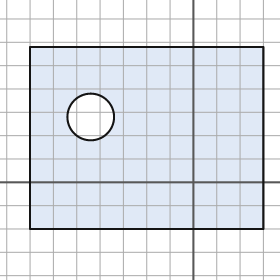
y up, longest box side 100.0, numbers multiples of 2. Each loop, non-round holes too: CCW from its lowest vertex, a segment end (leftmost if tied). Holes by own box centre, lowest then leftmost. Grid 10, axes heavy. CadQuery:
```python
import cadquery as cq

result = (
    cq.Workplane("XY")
    .moveTo(-70.0, -20.0)
    .lineTo(30.0, -20.0)
    .lineTo(30.0, 58.0)
    .lineTo(-70.0, 58.0)
    .close()
    .moveTo(-44.0, 28.0)
    .circle(10.0)
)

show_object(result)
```